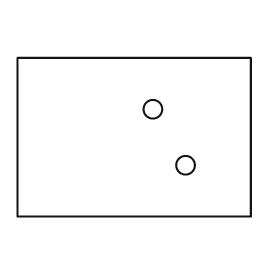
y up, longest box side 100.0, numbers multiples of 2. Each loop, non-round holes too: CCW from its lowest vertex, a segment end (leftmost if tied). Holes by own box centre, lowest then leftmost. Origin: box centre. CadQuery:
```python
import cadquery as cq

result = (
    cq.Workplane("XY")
    .moveTo(-50.0, -34.0)
    .lineTo(50.0, -34.0)
    .lineTo(50.0, 34.0)
    .lineTo(-50.0, 34.0)
    .close()
    .moveTo(22.0, -12.0)
    .circle(4.0)
    .moveTo(8.0, 12.0)
    .circle(4.0)
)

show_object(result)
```